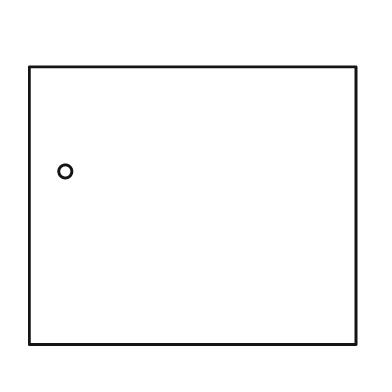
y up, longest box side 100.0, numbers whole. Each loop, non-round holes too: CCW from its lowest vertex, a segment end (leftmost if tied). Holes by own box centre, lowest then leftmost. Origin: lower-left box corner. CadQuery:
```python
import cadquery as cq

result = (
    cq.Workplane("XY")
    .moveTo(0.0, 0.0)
    .lineTo(100.0, 0.0)
    .lineTo(100.0, 85.0)
    .lineTo(0.0, 85.0)
    .close()
    .moveTo(11.0, 53.0)
    .circle(2.0)
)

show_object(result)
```